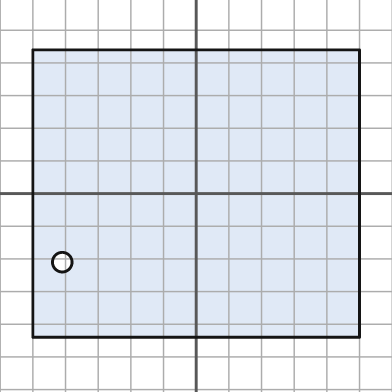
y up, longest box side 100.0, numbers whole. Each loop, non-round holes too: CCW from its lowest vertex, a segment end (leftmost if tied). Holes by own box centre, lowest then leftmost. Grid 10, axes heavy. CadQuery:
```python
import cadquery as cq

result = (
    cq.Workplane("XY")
    .moveTo(-50.0, -44.0)
    .lineTo(50.0, -44.0)
    .lineTo(50.0, 44.0)
    .lineTo(-50.0, 44.0)
    .close()
    .moveTo(-41.0, -21.0)
    .circle(3.0)
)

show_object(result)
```